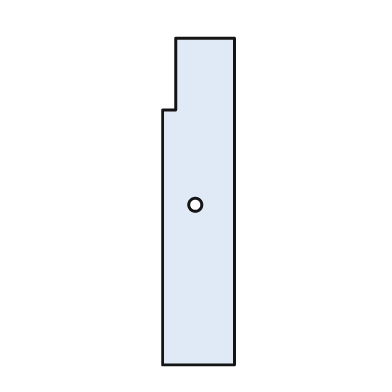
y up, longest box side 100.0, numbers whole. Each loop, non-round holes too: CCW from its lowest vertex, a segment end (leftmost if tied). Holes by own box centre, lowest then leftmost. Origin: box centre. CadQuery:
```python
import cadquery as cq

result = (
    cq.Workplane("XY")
    .moveTo(-11.0, -50.0)
    .lineTo(11.0, -50.0)
    .lineTo(11.0, 50.0)
    .lineTo(-7.0, 50.0)
    .lineTo(-7.0, 28.0)
    .lineTo(-11.0, 28.0)
    .close()
    .moveTo(-1.0, -1.0)
    .circle(2.0)
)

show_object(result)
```